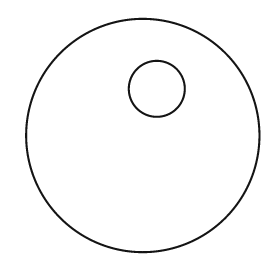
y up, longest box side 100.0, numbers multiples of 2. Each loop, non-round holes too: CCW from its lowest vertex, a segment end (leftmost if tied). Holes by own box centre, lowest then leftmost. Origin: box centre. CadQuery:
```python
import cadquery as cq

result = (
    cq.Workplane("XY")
    .moveTo(0.0, 0.0)
    .circle(50.0)
    .moveTo(6.0, 20.0)
    .circle(12.0)
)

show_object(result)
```